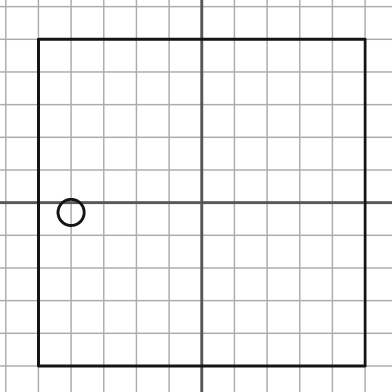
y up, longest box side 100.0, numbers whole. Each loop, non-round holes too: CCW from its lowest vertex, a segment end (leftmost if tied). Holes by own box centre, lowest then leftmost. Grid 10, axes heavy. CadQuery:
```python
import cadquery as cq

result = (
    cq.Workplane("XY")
    .moveTo(-50.0, -50.0)
    .lineTo(50.0, -50.0)
    .lineTo(50.0, 50.0)
    .lineTo(-50.0, 50.0)
    .close()
    .moveTo(-40.0, -3.0)
    .circle(4.0)
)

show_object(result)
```